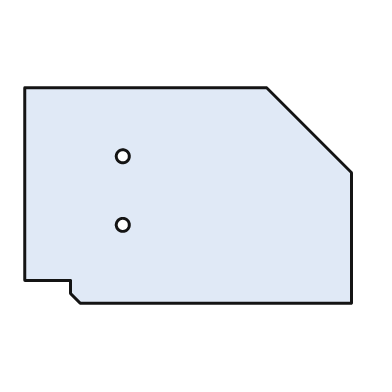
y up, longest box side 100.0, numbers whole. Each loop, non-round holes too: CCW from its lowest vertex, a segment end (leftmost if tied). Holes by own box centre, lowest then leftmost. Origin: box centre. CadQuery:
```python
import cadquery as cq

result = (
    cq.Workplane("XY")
    .moveTo(-33.0, -33.0)
    .lineTo(50.0, -33.0)
    .lineTo(50.0, 7.0)
    .lineTo(24.0, 33.0)
    .lineTo(-50.0, 33.0)
    .lineTo(-50.0, -26.0)
    .lineTo(-36.0, -26.0)
    .lineTo(-36.0, -30.0)
    .close()
    .moveTo(-20.0, -9.0)
    .circle(2.0)
    .moveTo(-20.0, 12.0)
    .circle(2.0)
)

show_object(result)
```